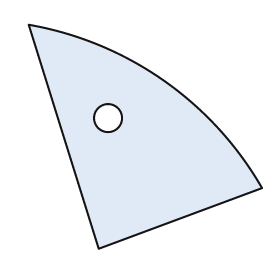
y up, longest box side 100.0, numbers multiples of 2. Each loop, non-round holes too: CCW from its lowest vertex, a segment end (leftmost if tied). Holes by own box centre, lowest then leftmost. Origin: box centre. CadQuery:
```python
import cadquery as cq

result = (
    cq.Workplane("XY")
    .moveTo(-20.0, -48.0)
    .lineTo(50.0, -22.0)
    .threePointArc((8.0, 24.0), (-50.0, 48.0))
    .close()
    .moveTo(-16.0, 8.0)
    .circle(6.0)
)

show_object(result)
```